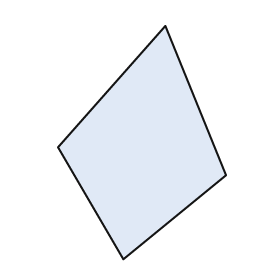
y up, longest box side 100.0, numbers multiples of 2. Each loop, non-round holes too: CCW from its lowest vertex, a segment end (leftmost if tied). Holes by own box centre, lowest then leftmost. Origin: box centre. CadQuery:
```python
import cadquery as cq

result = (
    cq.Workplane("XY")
    .moveTo(-8.0, -50.0)
    .lineTo(36.0, -14.0)
    .lineTo(10.0, 50.0)
    .lineTo(-36.0, -2.0)
    .close()
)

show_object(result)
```